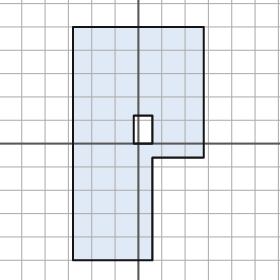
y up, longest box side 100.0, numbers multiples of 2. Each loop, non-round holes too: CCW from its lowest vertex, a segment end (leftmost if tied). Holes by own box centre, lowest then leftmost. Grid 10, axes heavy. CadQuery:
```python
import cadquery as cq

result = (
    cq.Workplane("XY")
    .moveTo(-28.0, -50.0)
    .lineTo(6.0, -50.0)
    .lineTo(6.0, -6.0)
    .lineTo(28.0, -6.0)
    .lineTo(28.0, 50.0)
    .lineTo(-28.0, 50.0)
    .close()
    .moveTo(-2.0, 0.0)
    .lineTo(6.0, 0.0)
    .lineTo(6.0, 12.0)
    .lineTo(-2.0, 12.0)
    .close()
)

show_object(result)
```